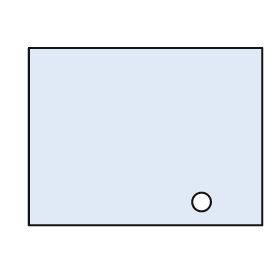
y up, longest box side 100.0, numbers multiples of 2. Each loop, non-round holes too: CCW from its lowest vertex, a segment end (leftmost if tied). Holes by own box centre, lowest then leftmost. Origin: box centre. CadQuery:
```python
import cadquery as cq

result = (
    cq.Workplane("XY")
    .moveTo(-50.0, -38.0)
    .lineTo(50.0, -38.0)
    .lineTo(50.0, 38.0)
    .lineTo(-50.0, 38.0)
    .close()
    .moveTo(24.0, -28.0)
    .circle(4.0)
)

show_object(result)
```